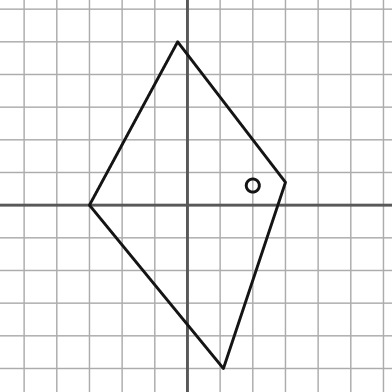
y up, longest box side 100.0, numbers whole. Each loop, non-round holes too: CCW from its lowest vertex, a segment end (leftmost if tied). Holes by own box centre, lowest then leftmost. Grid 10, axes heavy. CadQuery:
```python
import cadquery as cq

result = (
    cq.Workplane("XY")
    .moveTo(11.0, -50.0)
    .lineTo(30.0, 7.0)
    .lineTo(-3.0, 50.0)
    .lineTo(-30.0, 0.0)
    .close()
    .moveTo(20.0, 6.0)
    .circle(2.0)
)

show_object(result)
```